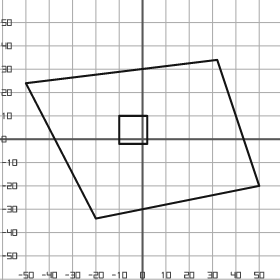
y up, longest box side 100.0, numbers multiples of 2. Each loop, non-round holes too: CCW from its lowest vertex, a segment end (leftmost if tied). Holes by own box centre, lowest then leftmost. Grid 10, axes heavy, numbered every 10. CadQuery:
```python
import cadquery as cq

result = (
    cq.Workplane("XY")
    .moveTo(-20.0, -34.0)
    .lineTo(50.0, -20.0)
    .lineTo(32.0, 34.0)
    .lineTo(-50.0, 24.0)
    .close()
    .moveTo(-10.0, -2.0)
    .lineTo(2.0, -2.0)
    .lineTo(2.0, 10.0)
    .lineTo(-10.0, 10.0)
    .close()
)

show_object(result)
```